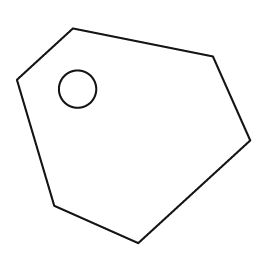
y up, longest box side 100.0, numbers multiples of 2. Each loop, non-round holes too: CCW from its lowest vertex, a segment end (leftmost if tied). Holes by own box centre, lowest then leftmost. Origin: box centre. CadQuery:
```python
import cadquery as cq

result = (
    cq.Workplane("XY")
    .moveTo(2.0, -46.0)
    .lineTo(50.0, -2.0)
    .lineTo(34.0, 34.0)
    .lineTo(-26.0, 46.0)
    .lineTo(-50.0, 24.0)
    .lineTo(-34.0, -30.0)
    .close()
    .moveTo(-24.0, 20.0)
    .circle(8.0)
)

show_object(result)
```